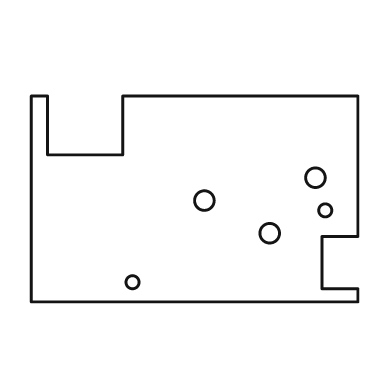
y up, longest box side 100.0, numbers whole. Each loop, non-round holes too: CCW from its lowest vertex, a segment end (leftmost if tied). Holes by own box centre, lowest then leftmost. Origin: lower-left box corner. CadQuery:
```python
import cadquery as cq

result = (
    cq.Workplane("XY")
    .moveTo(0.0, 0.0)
    .lineTo(100.0, 0.0)
    .lineTo(100.0, 4.0)
    .lineTo(89.0, 4.0)
    .lineTo(89.0, 20.0)
    .lineTo(100.0, 20.0)
    .lineTo(100.0, 63.0)
    .lineTo(28.0, 63.0)
    .lineTo(28.0, 45.0)
    .lineTo(5.0, 45.0)
    .lineTo(5.0, 63.0)
    .lineTo(0.0, 63.0)
    .close()
    .moveTo(31.0, 6.0)
    .circle(2.0)
    .moveTo(73.0, 21.0)
    .circle(3.0)
    .moveTo(90.0, 28.0)
    .circle(2.0)
    .moveTo(53.0, 31.0)
    .circle(3.0)
    .moveTo(87.0, 38.0)
    .circle(3.0)
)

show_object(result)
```